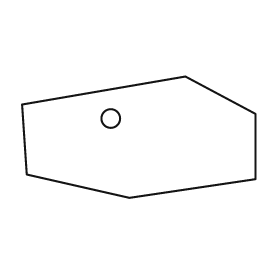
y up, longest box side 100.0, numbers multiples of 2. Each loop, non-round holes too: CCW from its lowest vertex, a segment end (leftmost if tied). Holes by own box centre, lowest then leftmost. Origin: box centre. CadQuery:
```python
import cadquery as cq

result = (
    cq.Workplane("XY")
    .moveTo(-4.0, -26.0)
    .lineTo(50.0, -18.0)
    .lineTo(50.0, 10.0)
    .lineTo(20.0, 26.0)
    .lineTo(-50.0, 14.0)
    .lineTo(-48.0, -16.0)
    .close()
    .moveTo(-12.0, 8.0)
    .circle(4.0)
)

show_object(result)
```